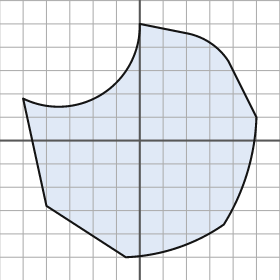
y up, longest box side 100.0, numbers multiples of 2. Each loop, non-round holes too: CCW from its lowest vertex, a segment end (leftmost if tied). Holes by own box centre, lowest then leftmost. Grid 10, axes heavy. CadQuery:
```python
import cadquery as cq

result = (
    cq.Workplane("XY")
    .moveTo(-6.0, -50.0)
    .threePointArc((16.0, -46.0), (36.0, -36.0))
    .threePointArc((46.0, -14.0), (50.0, 10.0))
    .lineTo(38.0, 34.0)
    .threePointArc((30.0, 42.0), (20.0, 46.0))
    .lineTo(0.0, 50.0)
    .threePointArc((-16.0, 20.0), (-50.0, 18.0))
    .lineTo(-40.0, -28.0)
    .close()
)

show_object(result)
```